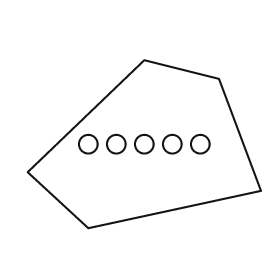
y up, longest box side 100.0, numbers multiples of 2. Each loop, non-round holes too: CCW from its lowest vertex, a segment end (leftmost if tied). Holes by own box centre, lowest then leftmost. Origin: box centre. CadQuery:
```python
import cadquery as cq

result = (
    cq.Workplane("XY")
    .moveTo(-24.0, -36.0)
    .lineTo(50.0, -20.0)
    .lineTo(32.0, 28.0)
    .lineTo(0.0, 36.0)
    .lineTo(-50.0, -12.0)
    .close()
    .moveTo(-24.0, 0.0)
    .circle(4.0)
    .moveTo(-12.0, 0.0)
    .circle(4.0)
    .moveTo(0.0, 0.0)
    .circle(4.0)
    .moveTo(12.0, 0.0)
    .circle(4.0)
    .moveTo(24.0, 0.0)
    .circle(4.0)
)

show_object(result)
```